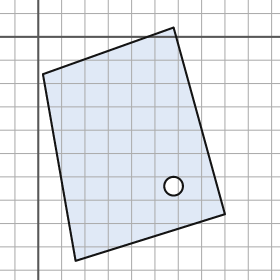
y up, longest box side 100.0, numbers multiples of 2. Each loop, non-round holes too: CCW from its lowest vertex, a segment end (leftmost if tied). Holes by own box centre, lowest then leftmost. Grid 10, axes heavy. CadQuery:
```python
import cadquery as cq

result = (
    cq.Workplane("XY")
    .moveTo(16.0, -96.0)
    .lineTo(80.0, -76.0)
    .lineTo(58.0, 4.0)
    .lineTo(2.0, -16.0)
    .close()
    .moveTo(58.0, -64.0)
    .circle(4.0)
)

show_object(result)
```